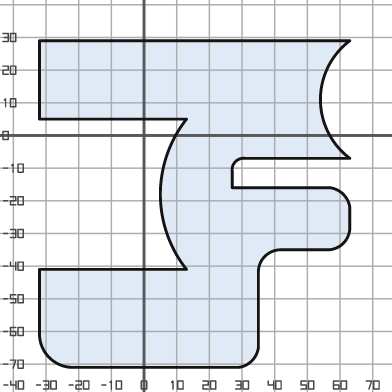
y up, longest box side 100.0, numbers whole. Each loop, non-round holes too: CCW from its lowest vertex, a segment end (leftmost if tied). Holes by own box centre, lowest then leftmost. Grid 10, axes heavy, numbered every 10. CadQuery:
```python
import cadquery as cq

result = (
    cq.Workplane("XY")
    .moveTo(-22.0, -71.0)
    .lineTo(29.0, -71.0)
    .threePointArc((33.0, -69.0), (35.0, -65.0))
    .lineTo(35.0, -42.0)
    .threePointArc((37.0, -37.0), (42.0, -35.0))
    .lineTo(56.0, -35.0)
    .threePointArc((61.0, -33.0), (63.0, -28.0))
    .lineTo(63.0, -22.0)
    .threePointArc((61.0, -18.0), (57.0, -16.0))
    .lineTo(27.0, -16.0)
    .lineTo(27.0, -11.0)
    .threePointArc((28.0, -8.0), (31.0, -7.0))
    .lineTo(63.0, -7.0)
    .threePointArc((54.0, 11.0), (63.0, 29.0))
    .lineTo(-32.0, 29.0)
    .lineTo(-32.0, 5.0)
    .lineTo(13.0, 5.0)
    .threePointArc((5.0, -18.0), (13.0, -41.0))
    .lineTo(-32.0, -41.0)
    .lineTo(-32.0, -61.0)
    .threePointArc((-29.0, -68.0), (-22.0, -71.0))
    .close()
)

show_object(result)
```